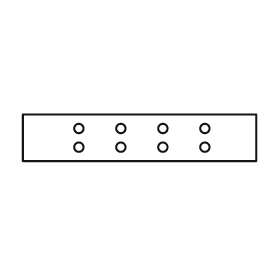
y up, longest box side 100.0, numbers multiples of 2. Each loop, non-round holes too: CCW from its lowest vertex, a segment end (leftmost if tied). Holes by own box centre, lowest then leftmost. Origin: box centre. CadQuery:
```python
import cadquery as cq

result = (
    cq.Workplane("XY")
    .moveTo(-50.0, -10.0)
    .lineTo(50.0, -10.0)
    .lineTo(50.0, 10.0)
    .lineTo(-50.0, 10.0)
    .close()
    .moveTo(-26.0, -4.0)
    .circle(2.0)
    .moveTo(-8.0, -4.0)
    .circle(2.0)
    .moveTo(10.0, -4.0)
    .circle(2.0)
    .moveTo(28.0, -4.0)
    .circle(2.0)
    .moveTo(-26.0, 4.0)
    .circle(2.0)
    .moveTo(-8.0, 4.0)
    .circle(2.0)
    .moveTo(10.0, 4.0)
    .circle(2.0)
    .moveTo(28.0, 4.0)
    .circle(2.0)
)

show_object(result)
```